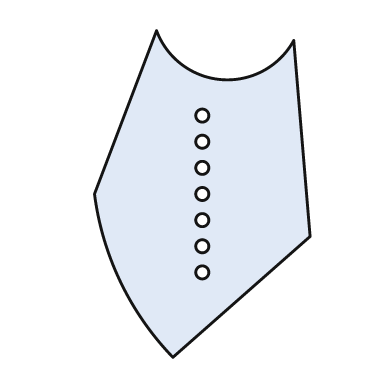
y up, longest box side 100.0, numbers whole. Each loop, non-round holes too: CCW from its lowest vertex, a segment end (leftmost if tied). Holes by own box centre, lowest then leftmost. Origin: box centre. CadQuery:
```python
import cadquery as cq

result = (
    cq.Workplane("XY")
    .moveTo(-9.0, -50.0)
    .lineTo(33.0, -13.0)
    .lineTo(28.0, 47.0)
    .threePointArc((6.0, 35.0), (-14.0, 50.0))
    .lineTo(-33.0, 0.0)
    .threePointArc((-25.0, -27.0), (-9.0, -50.0))
    .close()
    .moveTo(0.0, -24.0)
    .circle(2.0)
    .moveTo(0.0, -16.0)
    .circle(2.0)
    .moveTo(0.0, -8.0)
    .circle(2.0)
    .moveTo(0.0, 0.0)
    .circle(2.0)
    .moveTo(0.0, 8.0)
    .circle(2.0)
    .moveTo(0.0, 16.0)
    .circle(2.0)
    .moveTo(0.0, 24.0)
    .circle(2.0)
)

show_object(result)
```